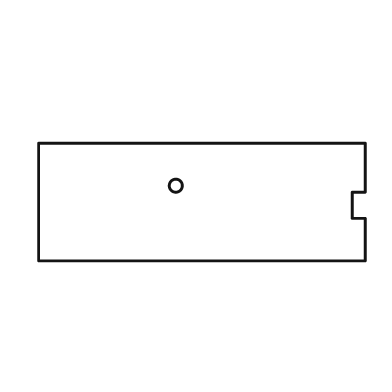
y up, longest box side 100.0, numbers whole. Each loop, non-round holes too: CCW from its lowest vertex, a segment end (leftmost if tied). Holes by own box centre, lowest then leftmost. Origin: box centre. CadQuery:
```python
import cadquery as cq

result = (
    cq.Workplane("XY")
    .moveTo(-50.0, -18.0)
    .lineTo(50.0, -18.0)
    .lineTo(50.0, -5.0)
    .lineTo(46.0, -5.0)
    .lineTo(46.0, 3.0)
    .lineTo(50.0, 3.0)
    .lineTo(50.0, 18.0)
    .lineTo(-50.0, 18.0)
    .close()
    .moveTo(-8.0, 5.0)
    .circle(2.0)
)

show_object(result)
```